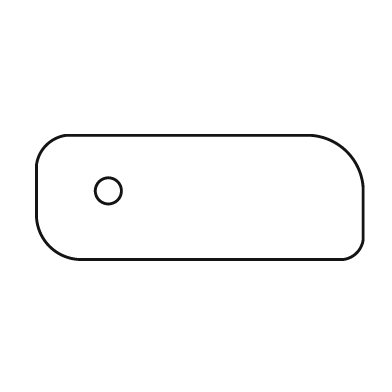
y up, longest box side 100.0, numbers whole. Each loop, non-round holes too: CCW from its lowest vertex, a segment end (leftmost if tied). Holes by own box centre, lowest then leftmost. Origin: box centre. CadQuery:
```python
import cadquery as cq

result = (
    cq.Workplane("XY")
    .moveTo(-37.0, -19.0)
    .lineTo(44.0, -19.0)
    .threePointArc((48.0, -17.0), (50.0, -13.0))
    .lineTo(50.0, 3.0)
    .threePointArc((45.0, 14.0), (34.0, 19.0))
    .lineTo(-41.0, 19.0)
    .threePointArc((-47.0, 16.0), (-50.0, 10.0))
    .lineTo(-50.0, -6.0)
    .threePointArc((-46.0, -15.0), (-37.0, -19.0))
    .close()
    .moveTo(-28.0, 2.0)
    .circle(4.0)
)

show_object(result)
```